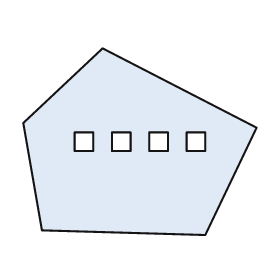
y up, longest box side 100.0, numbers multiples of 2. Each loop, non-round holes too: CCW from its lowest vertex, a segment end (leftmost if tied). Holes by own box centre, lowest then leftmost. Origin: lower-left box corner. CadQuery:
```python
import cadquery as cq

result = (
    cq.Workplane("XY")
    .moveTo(78.0, 0.0)
    .lineTo(100.0, 46.0)
    .lineTo(34.0, 80.0)
    .lineTo(0.0, 48.0)
    .lineTo(8.0, 2.0)
    .close()
    .moveTo(22.0, 36.0)
    .lineTo(30.0, 36.0)
    .lineTo(30.0, 44.0)
    .lineTo(22.0, 44.0)
    .close()
    .moveTo(38.0, 36.0)
    .lineTo(46.0, 36.0)
    .lineTo(46.0, 44.0)
    .lineTo(38.0, 44.0)
    .close()
    .moveTo(54.0, 36.0)
    .lineTo(62.0, 36.0)
    .lineTo(62.0, 44.0)
    .lineTo(54.0, 44.0)
    .close()
    .moveTo(70.0, 36.0)
    .lineTo(78.0, 36.0)
    .lineTo(78.0, 44.0)
    .lineTo(70.0, 44.0)
    .close()
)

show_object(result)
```